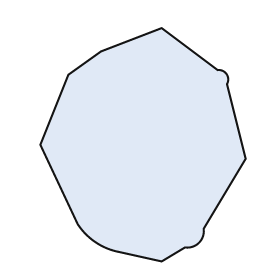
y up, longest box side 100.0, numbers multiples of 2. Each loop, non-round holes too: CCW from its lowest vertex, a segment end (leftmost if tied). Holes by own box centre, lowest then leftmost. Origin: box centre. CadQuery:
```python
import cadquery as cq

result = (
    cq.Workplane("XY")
    .moveTo(8.0, -50.0)
    .lineTo(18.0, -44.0)
    .threePointArc((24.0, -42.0), (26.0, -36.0))
    .lineTo(44.0, -6.0)
    .lineTo(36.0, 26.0)
    .threePointArc((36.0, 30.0), (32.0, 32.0))
    .lineTo(8.0, 50.0)
    .lineTo(-18.0, 40.0)
    .lineTo(-32.0, 30.0)
    .lineTo(-44.0, 0.0)
    .lineTo(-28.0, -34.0)
    .threePointArc((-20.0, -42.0), (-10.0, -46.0))
    .close()
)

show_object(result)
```